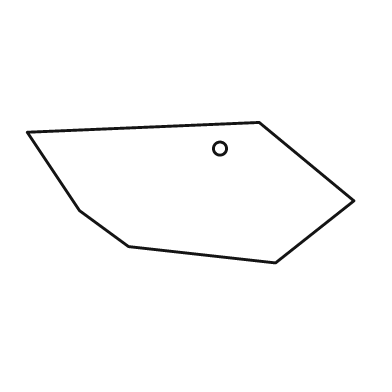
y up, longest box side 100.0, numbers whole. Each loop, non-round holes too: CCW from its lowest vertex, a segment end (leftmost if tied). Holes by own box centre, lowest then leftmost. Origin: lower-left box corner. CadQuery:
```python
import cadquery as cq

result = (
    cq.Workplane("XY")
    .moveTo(76.0, 0.0)
    .lineTo(100.0, 19.0)
    .lineTo(71.0, 43.0)
    .lineTo(0.0, 40.0)
    .lineTo(16.0, 16.0)
    .lineTo(31.0, 5.0)
    .close()
    .moveTo(59.0, 35.0)
    .circle(2.0)
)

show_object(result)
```